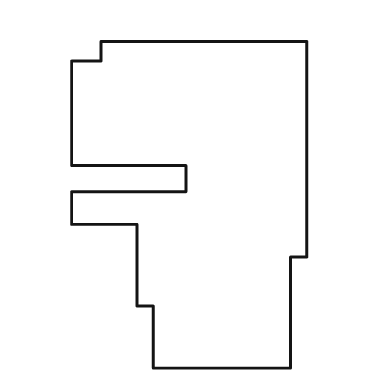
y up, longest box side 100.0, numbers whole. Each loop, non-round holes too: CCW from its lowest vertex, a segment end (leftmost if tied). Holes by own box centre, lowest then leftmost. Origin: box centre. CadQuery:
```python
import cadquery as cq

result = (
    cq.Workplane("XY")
    .moveTo(-11.0, -50.0)
    .lineTo(31.0, -50.0)
    .lineTo(31.0, -16.0)
    .lineTo(36.0, -16.0)
    .lineTo(36.0, 50.0)
    .lineTo(-27.0, 50.0)
    .lineTo(-27.0, 44.0)
    .lineTo(-36.0, 44.0)
    .lineTo(-36.0, 12.0)
    .lineTo(-1.0, 12.0)
    .lineTo(-1.0, 4.0)
    .lineTo(-36.0, 4.0)
    .lineTo(-36.0, -6.0)
    .lineTo(-16.0, -6.0)
    .lineTo(-16.0, -31.0)
    .lineTo(-11.0, -31.0)
    .close()
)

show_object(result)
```